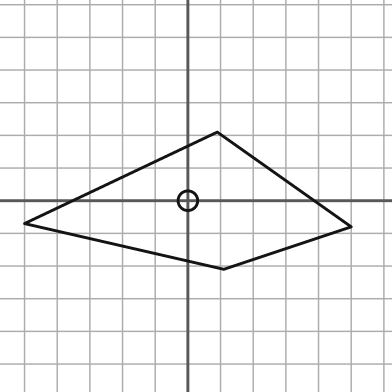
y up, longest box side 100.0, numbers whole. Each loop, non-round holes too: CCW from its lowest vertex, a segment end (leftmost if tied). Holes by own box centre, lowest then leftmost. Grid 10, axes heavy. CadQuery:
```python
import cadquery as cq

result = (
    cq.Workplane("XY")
    .moveTo(11.0, -21.0)
    .lineTo(50.0, -8.0)
    .lineTo(9.0, 21.0)
    .lineTo(-50.0, -7.0)
    .close()
    .moveTo(0.0, 0.0)
    .circle(3.0)
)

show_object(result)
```